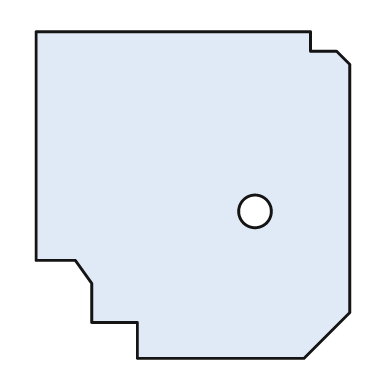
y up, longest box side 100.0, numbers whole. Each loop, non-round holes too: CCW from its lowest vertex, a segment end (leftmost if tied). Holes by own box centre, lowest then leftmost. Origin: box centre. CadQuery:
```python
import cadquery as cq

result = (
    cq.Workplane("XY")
    .moveTo(-17.0, -50.0)
    .lineTo(34.0, -50.0)
    .lineTo(48.0, -36.0)
    .lineTo(48.0, 40.0)
    .lineTo(44.0, 44.0)
    .lineTo(36.0, 44.0)
    .lineTo(36.0, 50.0)
    .lineTo(-48.0, 50.0)
    .lineTo(-48.0, -20.0)
    .lineTo(-36.0, -20.0)
    .lineTo(-31.0, -27.0)
    .lineTo(-31.0, -39.0)
    .lineTo(-17.0, -39.0)
    .close()
    .moveTo(19.0, -5.0)
    .circle(5.0)
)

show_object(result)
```